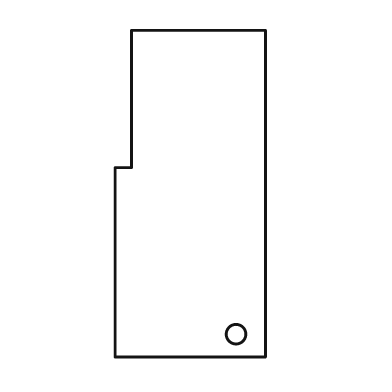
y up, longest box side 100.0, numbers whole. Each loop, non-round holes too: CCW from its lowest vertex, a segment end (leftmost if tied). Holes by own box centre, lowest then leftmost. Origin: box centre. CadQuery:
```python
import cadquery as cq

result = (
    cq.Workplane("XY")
    .moveTo(-23.0, -50.0)
    .lineTo(23.0, -50.0)
    .lineTo(23.0, 50.0)
    .lineTo(-18.0, 50.0)
    .lineTo(-18.0, 8.0)
    .lineTo(-23.0, 8.0)
    .close()
    .moveTo(14.0, -43.0)
    .circle(3.0)
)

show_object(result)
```